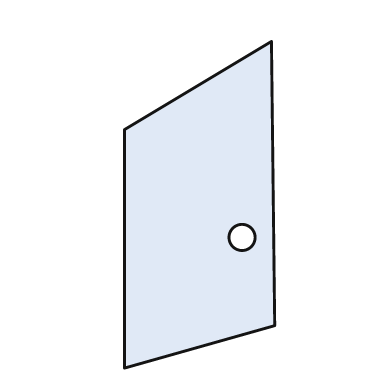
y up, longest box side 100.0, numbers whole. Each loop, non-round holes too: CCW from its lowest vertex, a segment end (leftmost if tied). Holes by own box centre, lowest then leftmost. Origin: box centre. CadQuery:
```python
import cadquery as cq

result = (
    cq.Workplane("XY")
    .moveTo(-23.0, -50.0)
    .lineTo(23.0, -37.0)
    .lineTo(22.0, 50.0)
    .lineTo(-23.0, 23.0)
    .close()
    .moveTo(13.0, -10.0)
    .circle(4.0)
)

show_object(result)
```